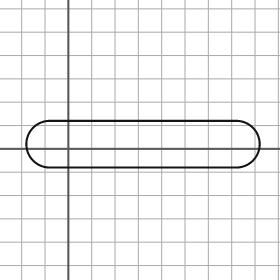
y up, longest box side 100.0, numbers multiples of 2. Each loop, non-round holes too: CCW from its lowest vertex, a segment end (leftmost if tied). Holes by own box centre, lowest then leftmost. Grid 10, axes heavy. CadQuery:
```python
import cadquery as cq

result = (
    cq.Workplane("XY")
    .moveTo(-8.0, -8.0)
    .lineTo(72.0, -8.0)
    .threePointArc((82.0, 2.0), (72.0, 12.0))
    .lineTo(-8.0, 12.0)
    .threePointArc((-18.0, 2.0), (-8.0, -8.0))
    .close()
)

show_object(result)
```